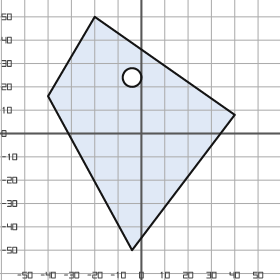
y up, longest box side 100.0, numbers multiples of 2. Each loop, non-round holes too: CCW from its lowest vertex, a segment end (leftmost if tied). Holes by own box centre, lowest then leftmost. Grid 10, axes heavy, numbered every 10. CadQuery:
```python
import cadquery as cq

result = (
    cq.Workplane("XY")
    .moveTo(-4.0, -50.0)
    .lineTo(40.0, 8.0)
    .lineTo(-20.0, 50.0)
    .lineTo(-40.0, 16.0)
    .close()
    .moveTo(-4.0, 24.0)
    .circle(4.0)
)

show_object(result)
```